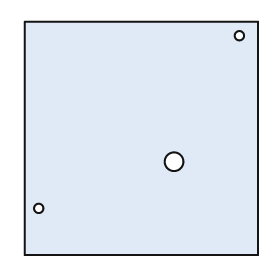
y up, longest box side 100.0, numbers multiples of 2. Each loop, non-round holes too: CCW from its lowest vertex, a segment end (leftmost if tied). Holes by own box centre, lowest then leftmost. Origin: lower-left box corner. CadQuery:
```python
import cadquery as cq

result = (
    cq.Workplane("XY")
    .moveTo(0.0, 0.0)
    .lineTo(100.0, 0.0)
    .lineTo(100.0, 100.0)
    .lineTo(0.0, 100.0)
    .close()
    .moveTo(6.0, 20.0)
    .circle(2.0)
    .moveTo(64.0, 40.0)
    .circle(4.0)
    .moveTo(92.0, 94.0)
    .circle(2.0)
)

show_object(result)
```